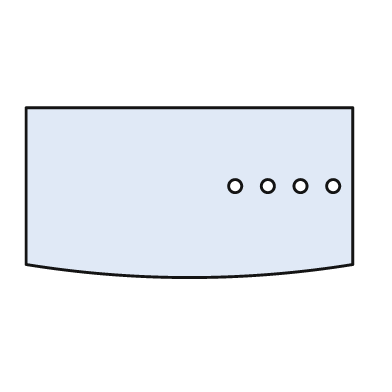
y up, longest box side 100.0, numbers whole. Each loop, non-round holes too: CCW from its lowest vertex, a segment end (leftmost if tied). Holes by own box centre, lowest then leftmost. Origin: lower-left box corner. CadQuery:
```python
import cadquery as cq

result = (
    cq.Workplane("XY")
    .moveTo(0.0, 4.0)
    .threePointArc((50.0, 0.0), (100.0, 4.0))
    .lineTo(100.0, 52.0)
    .lineTo(0.0, 52.0)
    .close()
    .moveTo(64.0, 28.0)
    .circle(2.0)
    .moveTo(74.0, 28.0)
    .circle(2.0)
    .moveTo(84.0, 28.0)
    .circle(2.0)
    .moveTo(94.0, 28.0)
    .circle(2.0)
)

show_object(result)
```